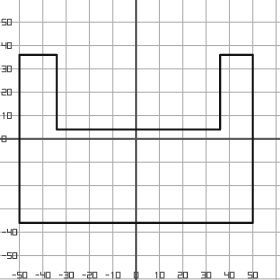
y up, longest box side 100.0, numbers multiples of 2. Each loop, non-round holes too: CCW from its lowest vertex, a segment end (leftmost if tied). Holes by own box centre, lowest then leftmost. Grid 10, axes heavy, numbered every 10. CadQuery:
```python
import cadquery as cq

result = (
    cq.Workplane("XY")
    .moveTo(-50.0, -36.0)
    .lineTo(50.0, -36.0)
    .lineTo(50.0, 36.0)
    .lineTo(36.0, 36.0)
    .lineTo(36.0, 4.0)
    .lineTo(-34.0, 4.0)
    .lineTo(-34.0, 36.0)
    .lineTo(-50.0, 36.0)
    .close()
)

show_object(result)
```